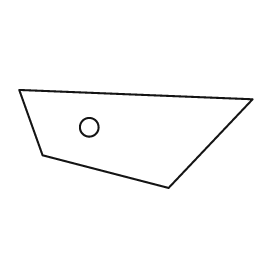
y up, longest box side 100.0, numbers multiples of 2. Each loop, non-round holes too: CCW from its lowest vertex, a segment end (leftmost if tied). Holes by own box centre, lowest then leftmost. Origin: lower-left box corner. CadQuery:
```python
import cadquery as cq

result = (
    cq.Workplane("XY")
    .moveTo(64.0, 0.0)
    .lineTo(100.0, 38.0)
    .lineTo(0.0, 42.0)
    .lineTo(10.0, 14.0)
    .close()
    .moveTo(30.0, 26.0)
    .circle(4.0)
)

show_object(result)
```